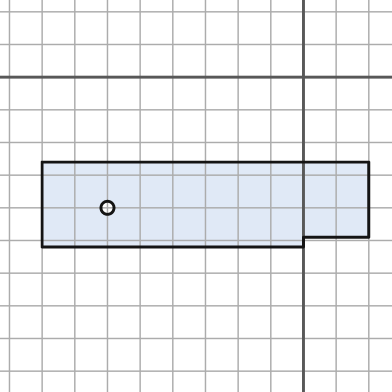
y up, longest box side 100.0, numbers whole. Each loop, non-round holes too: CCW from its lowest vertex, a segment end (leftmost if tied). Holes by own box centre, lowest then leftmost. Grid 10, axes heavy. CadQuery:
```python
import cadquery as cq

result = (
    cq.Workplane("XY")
    .moveTo(-80.0, -52.0)
    .lineTo(0.0, -52.0)
    .lineTo(0.0, -49.0)
    .lineTo(20.0, -49.0)
    .lineTo(20.0, -26.0)
    .lineTo(-80.0, -26.0)
    .close()
    .moveTo(-60.0, -40.0)
    .circle(2.0)
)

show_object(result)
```